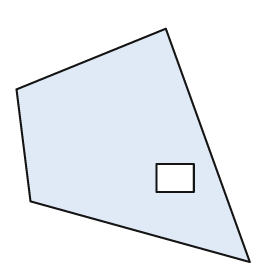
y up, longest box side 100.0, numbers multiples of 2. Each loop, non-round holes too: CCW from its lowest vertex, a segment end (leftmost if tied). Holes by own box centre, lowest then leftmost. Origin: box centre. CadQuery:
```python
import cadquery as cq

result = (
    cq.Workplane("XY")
    .moveTo(50.0, -50.0)
    .lineTo(14.0, 50.0)
    .lineTo(-50.0, 24.0)
    .lineTo(-44.0, -24.0)
    .close()
    .moveTo(10.0, -20.0)
    .lineTo(26.0, -20.0)
    .lineTo(26.0, -8.0)
    .lineTo(10.0, -8.0)
    .close()
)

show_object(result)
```